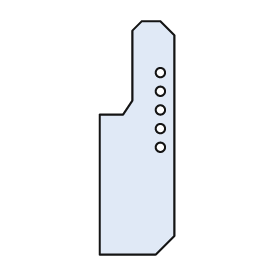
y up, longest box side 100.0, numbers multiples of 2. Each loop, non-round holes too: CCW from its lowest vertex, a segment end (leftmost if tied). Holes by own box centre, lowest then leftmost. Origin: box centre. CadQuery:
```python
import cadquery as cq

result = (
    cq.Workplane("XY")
    .moveTo(-16.0, -50.0)
    .lineTo(8.0, -50.0)
    .lineTo(16.0, -42.0)
    .lineTo(16.0, 44.0)
    .lineTo(10.0, 50.0)
    .lineTo(2.0, 50.0)
    .lineTo(-2.0, 46.0)
    .lineTo(-2.0, 16.0)
    .lineTo(-6.0, 10.0)
    .lineTo(-16.0, 10.0)
    .close()
    .moveTo(10.0, -4.0)
    .circle(2.0)
    .moveTo(10.0, 4.0)
    .circle(2.0)
    .moveTo(10.0, 12.0)
    .circle(2.0)
    .moveTo(10.0, 20.0)
    .circle(2.0)
    .moveTo(10.0, 28.0)
    .circle(2.0)
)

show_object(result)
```